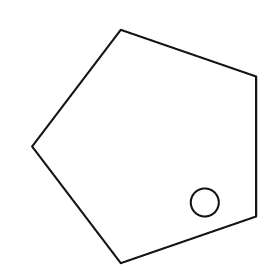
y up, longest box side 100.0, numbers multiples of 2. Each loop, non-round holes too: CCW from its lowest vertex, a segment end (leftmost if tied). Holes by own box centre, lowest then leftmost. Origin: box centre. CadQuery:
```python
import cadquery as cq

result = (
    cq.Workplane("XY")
    .moveTo(-10.0, -50.0)
    .lineTo(48.0, -30.0)
    .lineTo(48.0, 30.0)
    .lineTo(-10.0, 50.0)
    .lineTo(-48.0, 0.0)
    .close()
    .moveTo(26.0, -24.0)
    .circle(6.0)
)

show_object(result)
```